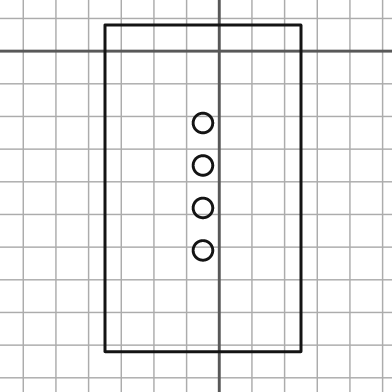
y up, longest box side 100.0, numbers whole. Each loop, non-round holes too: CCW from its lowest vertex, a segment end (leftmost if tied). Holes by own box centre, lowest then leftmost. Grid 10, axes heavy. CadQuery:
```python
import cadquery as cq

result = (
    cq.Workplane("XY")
    .moveTo(-35.0, -92.0)
    .lineTo(25.0, -92.0)
    .lineTo(25.0, 8.0)
    .lineTo(-35.0, 8.0)
    .close()
    .moveTo(-5.0, -61.0)
    .circle(3.0)
    .moveTo(-5.0, -48.0)
    .circle(3.0)
    .moveTo(-5.0, -35.0)
    .circle(3.0)
    .moveTo(-5.0, -22.0)
    .circle(3.0)
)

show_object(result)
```